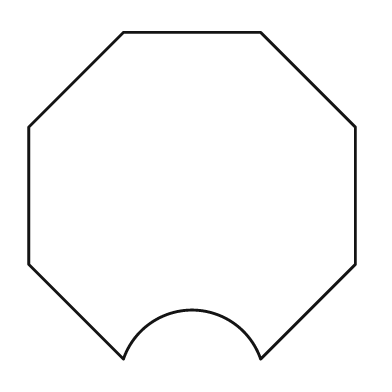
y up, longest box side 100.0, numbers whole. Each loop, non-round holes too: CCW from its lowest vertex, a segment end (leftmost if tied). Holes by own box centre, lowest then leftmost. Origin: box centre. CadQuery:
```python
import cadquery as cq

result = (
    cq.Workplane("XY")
    .moveTo(-21.0, -50.0)
    .threePointArc((0.0, -35.0), (21.0, -50.0))
    .lineTo(50.0, -21.0)
    .lineTo(50.0, 21.0)
    .lineTo(21.0, 50.0)
    .lineTo(-21.0, 50.0)
    .lineTo(-50.0, 21.0)
    .lineTo(-50.0, -21.0)
    .close()
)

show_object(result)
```